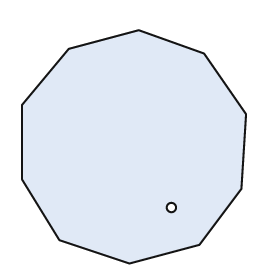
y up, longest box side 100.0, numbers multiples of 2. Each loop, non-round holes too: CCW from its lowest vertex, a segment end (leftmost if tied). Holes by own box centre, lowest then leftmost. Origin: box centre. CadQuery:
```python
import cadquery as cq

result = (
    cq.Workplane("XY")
    .moveTo(-2.0, -50.0)
    .lineTo(28.0, -42.0)
    .lineTo(46.0, -18.0)
    .lineTo(48.0, 14.0)
    .lineTo(30.0, 40.0)
    .lineTo(2.0, 50.0)
    .lineTo(-28.0, 42.0)
    .lineTo(-48.0, 18.0)
    .lineTo(-48.0, -14.0)
    .lineTo(-32.0, -40.0)
    .close()
    .moveTo(16.0, -26.0)
    .circle(2.0)
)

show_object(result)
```